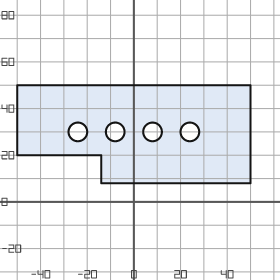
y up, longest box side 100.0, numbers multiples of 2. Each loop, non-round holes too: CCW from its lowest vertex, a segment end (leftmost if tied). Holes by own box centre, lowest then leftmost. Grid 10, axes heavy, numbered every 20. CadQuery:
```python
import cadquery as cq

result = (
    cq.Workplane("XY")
    .moveTo(-14.0, 8.0)
    .lineTo(50.0, 8.0)
    .lineTo(50.0, 50.0)
    .lineTo(-50.0, 50.0)
    .lineTo(-50.0, 20.0)
    .lineTo(-14.0, 20.0)
    .close()
    .moveTo(-24.0, 30.0)
    .circle(4.0)
    .moveTo(-8.0, 30.0)
    .circle(4.0)
    .moveTo(8.0, 30.0)
    .circle(4.0)
    .moveTo(24.0, 30.0)
    .circle(4.0)
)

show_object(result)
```